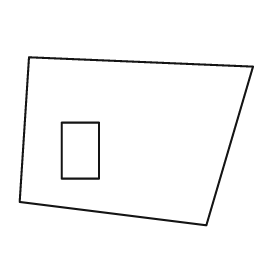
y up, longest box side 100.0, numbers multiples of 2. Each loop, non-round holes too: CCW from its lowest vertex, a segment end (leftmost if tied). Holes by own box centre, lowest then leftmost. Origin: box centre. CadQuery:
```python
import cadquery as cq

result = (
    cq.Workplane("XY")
    .moveTo(30.0, -36.0)
    .lineTo(50.0, 32.0)
    .lineTo(-46.0, 36.0)
    .lineTo(-50.0, -26.0)
    .close()
    .moveTo(-32.0, -16.0)
    .lineTo(-16.0, -16.0)
    .lineTo(-16.0, 8.0)
    .lineTo(-32.0, 8.0)
    .close()
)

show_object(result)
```